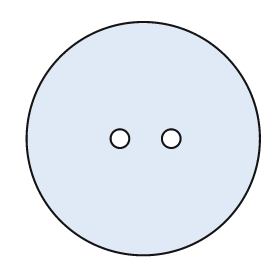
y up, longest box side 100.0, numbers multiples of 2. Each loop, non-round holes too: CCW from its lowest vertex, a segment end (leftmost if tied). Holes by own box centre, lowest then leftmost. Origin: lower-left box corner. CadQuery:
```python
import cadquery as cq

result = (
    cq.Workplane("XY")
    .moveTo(50.0, 50.0)
    .circle(50.0)
    .moveTo(40.0, 50.0)
    .circle(4.0)
    .moveTo(62.0, 50.0)
    .circle(4.0)
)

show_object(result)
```